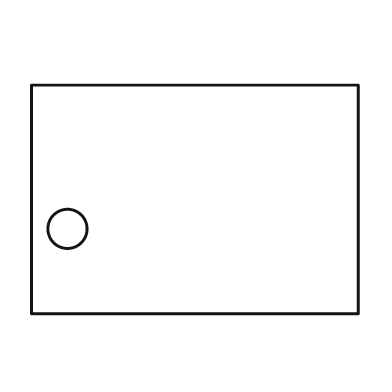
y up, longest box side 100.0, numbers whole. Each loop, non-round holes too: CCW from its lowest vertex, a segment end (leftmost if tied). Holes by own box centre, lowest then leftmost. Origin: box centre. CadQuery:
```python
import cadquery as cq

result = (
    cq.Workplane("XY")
    .moveTo(-50.0, -35.0)
    .lineTo(50.0, -35.0)
    .lineTo(50.0, 35.0)
    .lineTo(-50.0, 35.0)
    .close()
    .moveTo(-39.0, -9.0)
    .circle(6.0)
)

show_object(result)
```